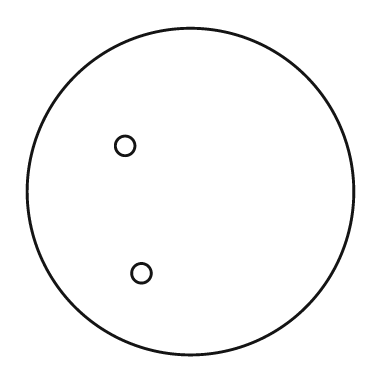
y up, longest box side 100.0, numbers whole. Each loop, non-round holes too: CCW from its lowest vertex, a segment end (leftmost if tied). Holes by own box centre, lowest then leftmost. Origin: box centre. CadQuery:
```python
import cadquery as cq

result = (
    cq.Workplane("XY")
    .moveTo(0.0, 0.0)
    .circle(50.0)
    .moveTo(-15.0, -25.0)
    .circle(3.0)
    .moveTo(-20.0, 14.0)
    .circle(3.0)
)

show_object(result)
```